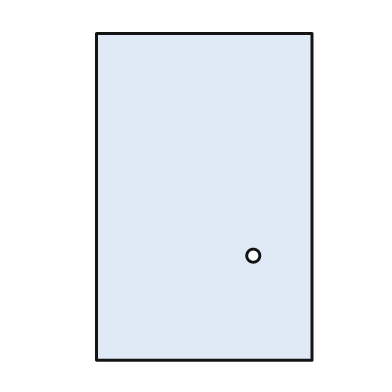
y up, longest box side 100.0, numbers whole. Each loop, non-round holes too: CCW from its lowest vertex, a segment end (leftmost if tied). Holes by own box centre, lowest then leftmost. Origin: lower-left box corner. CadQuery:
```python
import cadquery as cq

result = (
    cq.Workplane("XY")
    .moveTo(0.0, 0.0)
    .lineTo(66.0, 0.0)
    .lineTo(66.0, 100.0)
    .lineTo(0.0, 100.0)
    .close()
    .moveTo(48.0, 32.0)
    .circle(2.0)
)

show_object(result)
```